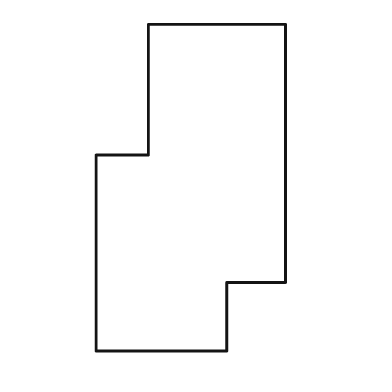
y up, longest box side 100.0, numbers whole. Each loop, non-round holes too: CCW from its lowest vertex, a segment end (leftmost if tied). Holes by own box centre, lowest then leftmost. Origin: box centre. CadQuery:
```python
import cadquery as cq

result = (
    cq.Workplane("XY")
    .moveTo(-29.0, -50.0)
    .lineTo(11.0, -50.0)
    .lineTo(11.0, -29.0)
    .lineTo(29.0, -29.0)
    .lineTo(29.0, 50.0)
    .lineTo(-13.0, 50.0)
    .lineTo(-13.0, 10.0)
    .lineTo(-29.0, 10.0)
    .close()
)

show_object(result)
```